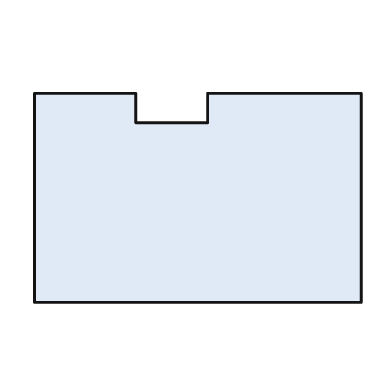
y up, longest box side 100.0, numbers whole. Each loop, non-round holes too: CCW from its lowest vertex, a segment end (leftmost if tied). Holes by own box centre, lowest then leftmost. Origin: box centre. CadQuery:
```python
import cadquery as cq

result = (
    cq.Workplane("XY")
    .moveTo(-50.0, -32.0)
    .lineTo(50.0, -32.0)
    .lineTo(50.0, 32.0)
    .lineTo(3.0, 32.0)
    .lineTo(3.0, 23.0)
    .lineTo(-19.0, 23.0)
    .lineTo(-19.0, 32.0)
    .lineTo(-50.0, 32.0)
    .close()
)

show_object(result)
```